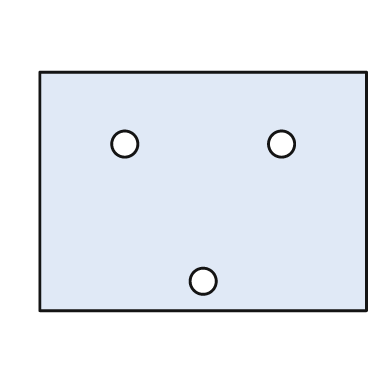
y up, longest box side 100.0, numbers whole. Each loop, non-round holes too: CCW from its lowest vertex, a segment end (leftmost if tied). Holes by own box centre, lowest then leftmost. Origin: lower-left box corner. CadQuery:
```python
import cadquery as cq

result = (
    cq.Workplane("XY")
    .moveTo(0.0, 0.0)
    .lineTo(100.0, 0.0)
    .lineTo(100.0, 73.0)
    .lineTo(0.0, 73.0)
    .close()
    .moveTo(50.0, 9.0)
    .circle(4.0)
    .moveTo(26.0, 51.0)
    .circle(4.0)
    .moveTo(74.0, 51.0)
    .circle(4.0)
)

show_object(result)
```